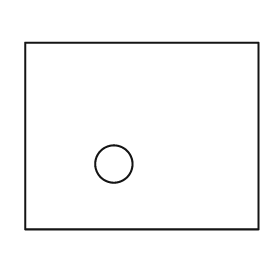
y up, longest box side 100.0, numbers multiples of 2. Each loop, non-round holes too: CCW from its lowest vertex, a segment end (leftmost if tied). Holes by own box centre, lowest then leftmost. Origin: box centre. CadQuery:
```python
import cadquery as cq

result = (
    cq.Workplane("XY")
    .moveTo(-50.0, -40.0)
    .lineTo(50.0, -40.0)
    .lineTo(50.0, 40.0)
    .lineTo(-50.0, 40.0)
    .close()
    .moveTo(-12.0, -12.0)
    .circle(8.0)
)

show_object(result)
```